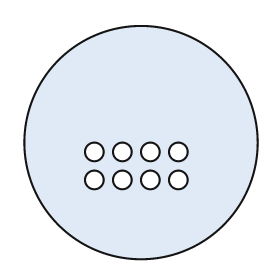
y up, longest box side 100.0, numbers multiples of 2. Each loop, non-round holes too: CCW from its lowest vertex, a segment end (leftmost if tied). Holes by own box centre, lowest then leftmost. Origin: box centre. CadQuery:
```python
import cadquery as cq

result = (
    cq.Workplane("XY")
    .moveTo(0.0, 0.0)
    .circle(50.0)
    .moveTo(-20.0, -16.0)
    .circle(4.0)
    .moveTo(-8.0, -16.0)
    .circle(4.0)
    .moveTo(4.0, -16.0)
    .circle(4.0)
    .moveTo(16.0, -16.0)
    .circle(4.0)
    .moveTo(-20.0, -4.0)
    .circle(4.0)
    .moveTo(-8.0, -4.0)
    .circle(4.0)
    .moveTo(4.0, -4.0)
    .circle(4.0)
    .moveTo(16.0, -4.0)
    .circle(4.0)
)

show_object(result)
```